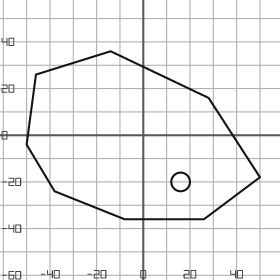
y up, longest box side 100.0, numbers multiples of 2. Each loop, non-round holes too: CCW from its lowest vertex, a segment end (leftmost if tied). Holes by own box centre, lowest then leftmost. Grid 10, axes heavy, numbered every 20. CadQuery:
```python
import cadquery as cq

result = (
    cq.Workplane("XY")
    .moveTo(-8.0, -36.0)
    .lineTo(26.0, -36.0)
    .lineTo(50.0, -18.0)
    .lineTo(28.0, 16.0)
    .lineTo(-14.0, 36.0)
    .lineTo(-46.0, 26.0)
    .lineTo(-50.0, -4.0)
    .lineTo(-38.0, -24.0)
    .close()
    .moveTo(16.0, -20.0)
    .circle(4.0)
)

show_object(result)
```